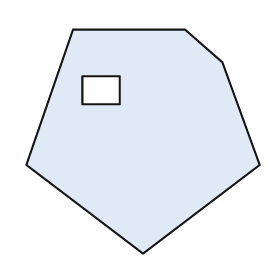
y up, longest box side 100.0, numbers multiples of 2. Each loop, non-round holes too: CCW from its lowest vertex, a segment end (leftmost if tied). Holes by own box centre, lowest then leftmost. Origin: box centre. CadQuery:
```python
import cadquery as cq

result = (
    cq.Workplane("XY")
    .moveTo(0.0, -48.0)
    .lineTo(50.0, -10.0)
    .lineTo(34.0, 34.0)
    .lineTo(18.0, 48.0)
    .lineTo(-30.0, 48.0)
    .lineTo(-50.0, -10.0)
    .close()
    .moveTo(-26.0, 16.0)
    .lineTo(-10.0, 16.0)
    .lineTo(-10.0, 28.0)
    .lineTo(-26.0, 28.0)
    .close()
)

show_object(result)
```